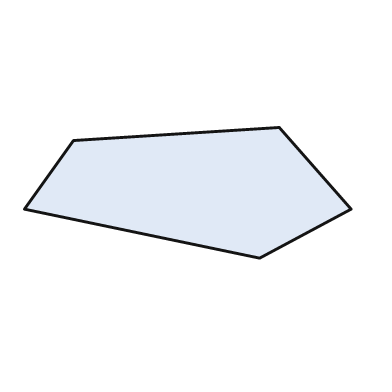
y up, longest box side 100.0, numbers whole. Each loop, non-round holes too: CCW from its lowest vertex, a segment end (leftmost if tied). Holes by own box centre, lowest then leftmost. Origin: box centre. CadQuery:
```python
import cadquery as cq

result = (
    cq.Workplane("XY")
    .moveTo(22.0, -20.0)
    .lineTo(50.0, -5.0)
    .lineTo(28.0, 20.0)
    .lineTo(-35.0, 16.0)
    .lineTo(-50.0, -5.0)
    .close()
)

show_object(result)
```